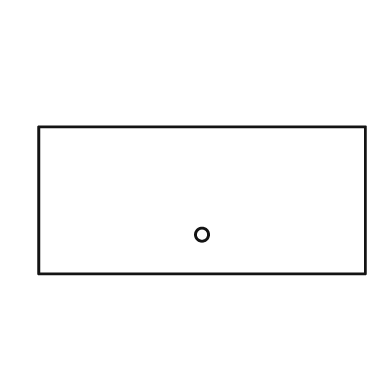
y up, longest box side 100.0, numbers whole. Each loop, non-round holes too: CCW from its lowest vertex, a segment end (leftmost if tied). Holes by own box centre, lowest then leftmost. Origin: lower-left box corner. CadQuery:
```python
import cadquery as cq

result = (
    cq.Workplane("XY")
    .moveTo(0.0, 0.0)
    .lineTo(100.0, 0.0)
    .lineTo(100.0, 45.0)
    .lineTo(0.0, 45.0)
    .close()
    .moveTo(50.0, 12.0)
    .circle(2.0)
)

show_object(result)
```